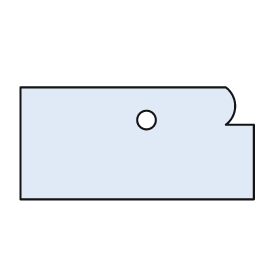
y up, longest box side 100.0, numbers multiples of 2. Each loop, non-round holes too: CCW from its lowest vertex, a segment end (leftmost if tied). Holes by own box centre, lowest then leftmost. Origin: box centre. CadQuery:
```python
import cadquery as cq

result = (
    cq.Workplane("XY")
    .moveTo(-50.0, -24.0)
    .lineTo(50.0, -24.0)
    .lineTo(50.0, 8.0)
    .lineTo(38.0, 8.0)
    .threePointArc((42.0, 16.0), (38.0, 24.0))
    .lineTo(-50.0, 24.0)
    .close()
    .moveTo(4.0, 10.0)
    .circle(4.0)
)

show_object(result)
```